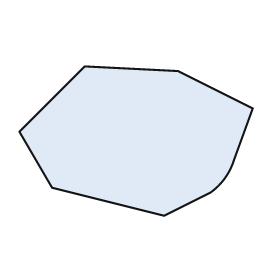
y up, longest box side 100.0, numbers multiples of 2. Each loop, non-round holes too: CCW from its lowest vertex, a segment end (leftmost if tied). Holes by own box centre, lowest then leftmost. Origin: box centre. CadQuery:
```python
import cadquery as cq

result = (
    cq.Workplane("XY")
    .moveTo(12.0, -32.0)
    .lineTo(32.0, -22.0)
    .threePointArc((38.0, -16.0), (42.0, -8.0))
    .lineTo(50.0, 14.0)
    .lineTo(18.0, 30.0)
    .lineTo(-22.0, 32.0)
    .lineTo(-50.0, 4.0)
    .lineTo(-36.0, -20.0)
    .close()
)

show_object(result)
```